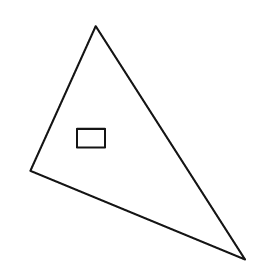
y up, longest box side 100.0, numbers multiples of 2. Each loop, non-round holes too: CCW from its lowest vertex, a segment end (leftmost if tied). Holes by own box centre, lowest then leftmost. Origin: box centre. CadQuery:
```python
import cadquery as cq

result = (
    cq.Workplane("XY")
    .moveTo(46.0, -50.0)
    .lineTo(-18.0, 50.0)
    .lineTo(-46.0, -12.0)
    .close()
    .moveTo(-26.0, -2.0)
    .lineTo(-14.0, -2.0)
    .lineTo(-14.0, 6.0)
    .lineTo(-26.0, 6.0)
    .close()
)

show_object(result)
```